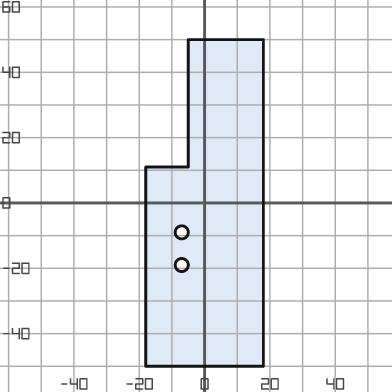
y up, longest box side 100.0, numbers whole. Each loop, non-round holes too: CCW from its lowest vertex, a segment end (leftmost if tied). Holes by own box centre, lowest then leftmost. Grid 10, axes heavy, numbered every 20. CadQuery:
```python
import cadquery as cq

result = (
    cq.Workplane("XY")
    .moveTo(-18.0, -50.0)
    .lineTo(18.0, -50.0)
    .lineTo(18.0, 50.0)
    .lineTo(-5.0, 50.0)
    .lineTo(-5.0, 11.0)
    .lineTo(-18.0, 11.0)
    .close()
    .moveTo(-7.0, -19.0)
    .circle(2.0)
    .moveTo(-7.0, -9.0)
    .circle(2.0)
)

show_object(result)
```